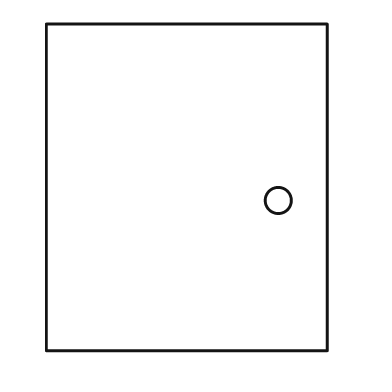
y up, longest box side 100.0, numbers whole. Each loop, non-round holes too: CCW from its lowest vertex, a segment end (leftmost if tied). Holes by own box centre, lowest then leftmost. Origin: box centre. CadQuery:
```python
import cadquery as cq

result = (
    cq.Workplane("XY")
    .moveTo(-43.0, -50.0)
    .lineTo(43.0, -50.0)
    .lineTo(43.0, 50.0)
    .lineTo(-43.0, 50.0)
    .close()
    .moveTo(28.0, -4.0)
    .circle(4.0)
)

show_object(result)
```